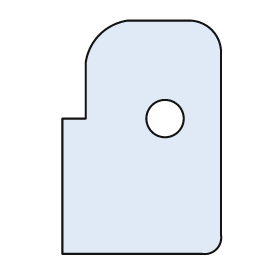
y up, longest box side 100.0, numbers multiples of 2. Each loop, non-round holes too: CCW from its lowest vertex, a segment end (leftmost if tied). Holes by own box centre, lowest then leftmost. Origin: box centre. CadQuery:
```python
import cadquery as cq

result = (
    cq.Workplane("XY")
    .moveTo(-34.0, -50.0)
    .lineTo(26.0, -50.0)
    .threePointArc((32.0, -48.0), (34.0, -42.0))
    .lineTo(34.0, 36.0)
    .threePointArc((30.0, 46.0), (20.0, 50.0))
    .lineTo(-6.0, 50.0)
    .threePointArc((-18.0, 44.0), (-24.0, 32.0))
    .lineTo(-24.0, 8.0)
    .lineTo(-34.0, 8.0)
    .close()
    .moveTo(10.0, 8.0)
    .circle(8.0)
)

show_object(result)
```